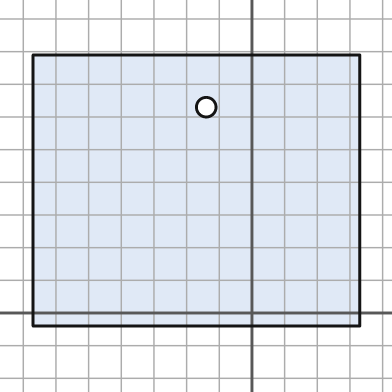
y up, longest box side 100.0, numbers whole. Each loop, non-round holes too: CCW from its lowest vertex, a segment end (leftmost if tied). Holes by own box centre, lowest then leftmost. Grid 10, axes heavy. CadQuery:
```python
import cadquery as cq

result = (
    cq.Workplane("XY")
    .moveTo(-67.0, -4.0)
    .lineTo(33.0, -4.0)
    .lineTo(33.0, 79.0)
    .lineTo(-67.0, 79.0)
    .close()
    .moveTo(-14.0, 63.0)
    .circle(3.0)
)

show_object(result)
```